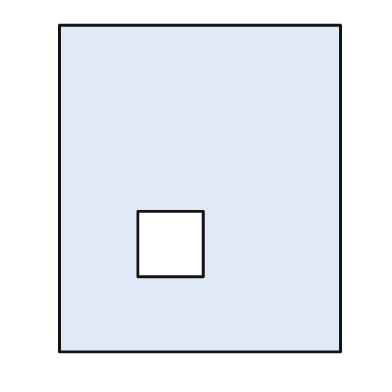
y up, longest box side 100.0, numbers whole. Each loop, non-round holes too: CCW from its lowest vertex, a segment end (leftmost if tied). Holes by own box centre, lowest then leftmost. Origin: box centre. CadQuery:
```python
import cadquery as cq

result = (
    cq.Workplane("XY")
    .moveTo(-43.0, -50.0)
    .lineTo(43.0, -50.0)
    .lineTo(43.0, 50.0)
    .lineTo(-43.0, 50.0)
    .close()
    .moveTo(-19.0, -27.0)
    .lineTo(1.0, -27.0)
    .lineTo(1.0, -7.0)
    .lineTo(-19.0, -7.0)
    .close()
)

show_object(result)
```